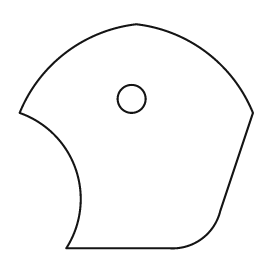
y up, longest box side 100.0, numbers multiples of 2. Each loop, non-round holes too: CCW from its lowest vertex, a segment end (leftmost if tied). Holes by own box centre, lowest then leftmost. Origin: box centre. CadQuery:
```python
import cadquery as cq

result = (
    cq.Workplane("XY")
    .moveTo(-30.0, -48.0)
    .lineTo(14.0, -48.0)
    .threePointArc((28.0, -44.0), (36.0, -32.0))
    .lineTo(50.0, 10.0)
    .threePointArc((30.0, 36.0), (0.0, 48.0))
    .threePointArc((-30.0, 36.0), (-50.0, 10.0))
    .threePointArc((-26.0, -14.0), (-30.0, -48.0))
    .close()
    .moveTo(-2.0, 16.0)
    .circle(6.0)
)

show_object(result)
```